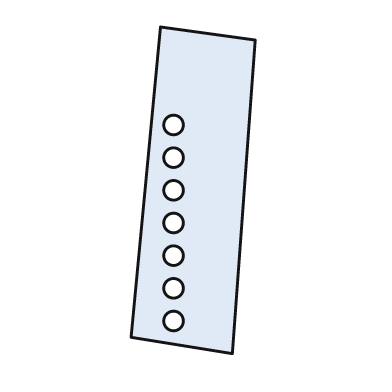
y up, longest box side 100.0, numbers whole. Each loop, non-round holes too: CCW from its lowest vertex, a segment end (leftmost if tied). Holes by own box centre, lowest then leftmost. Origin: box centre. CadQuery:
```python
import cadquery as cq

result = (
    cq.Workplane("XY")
    .moveTo(12.0, -50.0)
    .lineTo(19.0, 46.0)
    .lineTo(-10.0, 50.0)
    .lineTo(-19.0, -45.0)
    .close()
    .moveTo(-6.0, -40.0)
    .circle(3.0)
    .moveTo(-6.0, -30.0)
    .circle(3.0)
    .moveTo(-6.0, -20.0)
    .circle(3.0)
    .moveTo(-6.0, -10.0)
    .circle(3.0)
    .moveTo(-6.0, 0.0)
    .circle(3.0)
    .moveTo(-6.0, 10.0)
    .circle(3.0)
    .moveTo(-6.0, 20.0)
    .circle(3.0)
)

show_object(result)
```